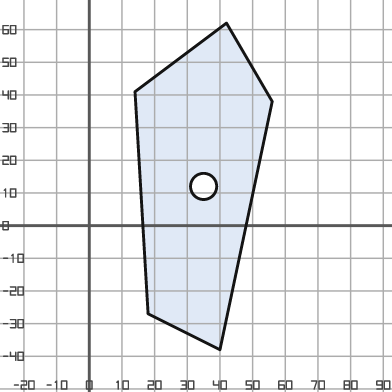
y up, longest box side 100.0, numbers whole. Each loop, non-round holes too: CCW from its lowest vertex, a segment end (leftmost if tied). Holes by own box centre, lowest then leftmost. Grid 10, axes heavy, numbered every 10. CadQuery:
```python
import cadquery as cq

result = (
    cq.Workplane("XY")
    .moveTo(40.0, -38.0)
    .lineTo(56.0, 38.0)
    .lineTo(42.0, 62.0)
    .lineTo(14.0, 41.0)
    .lineTo(18.0, -27.0)
    .close()
    .moveTo(35.0, 12.0)
    .circle(4.0)
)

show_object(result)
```